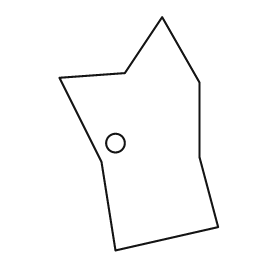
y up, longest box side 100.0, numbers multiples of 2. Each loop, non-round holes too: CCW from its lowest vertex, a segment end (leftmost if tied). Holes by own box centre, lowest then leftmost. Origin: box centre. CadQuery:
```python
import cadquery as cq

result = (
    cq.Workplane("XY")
    .moveTo(-10.0, -50.0)
    .lineTo(34.0, -40.0)
    .lineTo(26.0, -10.0)
    .lineTo(26.0, 22.0)
    .lineTo(10.0, 50.0)
    .lineTo(-6.0, 26.0)
    .lineTo(-34.0, 24.0)
    .lineTo(-16.0, -12.0)
    .close()
    .moveTo(-10.0, -4.0)
    .circle(4.0)
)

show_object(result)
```